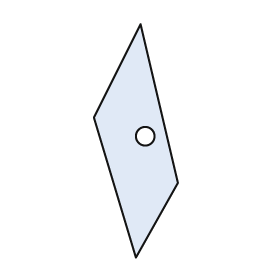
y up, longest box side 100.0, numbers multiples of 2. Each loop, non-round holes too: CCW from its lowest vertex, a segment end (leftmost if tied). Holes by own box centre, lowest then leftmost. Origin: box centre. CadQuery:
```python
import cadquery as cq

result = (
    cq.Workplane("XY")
    .moveTo(0.0, -50.0)
    .lineTo(18.0, -18.0)
    .lineTo(2.0, 50.0)
    .lineTo(-18.0, 10.0)
    .close()
    .moveTo(4.0, 2.0)
    .circle(4.0)
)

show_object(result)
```